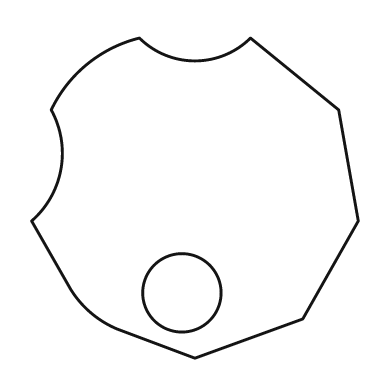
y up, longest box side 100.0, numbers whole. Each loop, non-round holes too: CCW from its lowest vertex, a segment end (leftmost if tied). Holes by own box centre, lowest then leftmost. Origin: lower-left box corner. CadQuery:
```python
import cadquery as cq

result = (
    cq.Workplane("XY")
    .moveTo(50.0, 0.0)
    .lineTo(83.0, 12.0)
    .lineTo(100.0, 42.0)
    .lineTo(94.0, 76.0)
    .lineTo(67.0, 98.0)
    .threePointArc((50.0, 91.0), (33.0, 98.0))
    .threePointArc((17.0, 90.0), (6.0, 76.0))
    .threePointArc((9.0, 58.0), (0.0, 42.0))
    .lineTo(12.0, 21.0)
    .threePointArc((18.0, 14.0), (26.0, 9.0))
    .close()
    .moveTo(46.0, 20.0)
    .circle(12.0)
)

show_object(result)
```